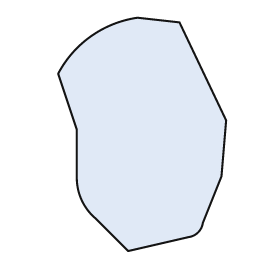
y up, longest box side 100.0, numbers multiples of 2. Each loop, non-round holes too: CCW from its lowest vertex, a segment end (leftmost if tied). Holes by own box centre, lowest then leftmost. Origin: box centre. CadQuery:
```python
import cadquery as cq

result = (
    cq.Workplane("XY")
    .moveTo(-6.0, -50.0)
    .lineTo(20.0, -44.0)
    .threePointArc((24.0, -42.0), (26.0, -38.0))
    .lineTo(34.0, -18.0)
    .lineTo(36.0, 6.0)
    .lineTo(16.0, 48.0)
    .lineTo(-2.0, 50.0)
    .threePointArc((-22.0, 42.0), (-36.0, 26.0))
    .lineTo(-28.0, 2.0)
    .lineTo(-28.0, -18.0)
    .threePointArc((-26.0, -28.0), (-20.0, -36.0))
    .close()
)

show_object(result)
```